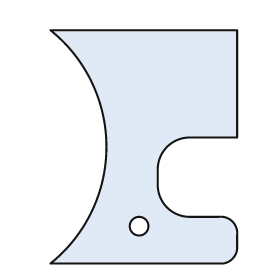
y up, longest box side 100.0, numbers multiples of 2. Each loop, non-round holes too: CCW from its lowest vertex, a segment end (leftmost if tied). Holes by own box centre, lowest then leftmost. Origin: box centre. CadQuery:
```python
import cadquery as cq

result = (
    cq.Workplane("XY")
    .moveTo(-40.0, -50.0)
    .lineTo(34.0, -50.0)
    .threePointArc((38.0, -48.0), (40.0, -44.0))
    .lineTo(40.0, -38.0)
    .threePointArc((38.0, -32.0), (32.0, -30.0))
    .lineTo(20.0, -30.0)
    .threePointArc((10.0, -26.0), (6.0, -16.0))
    .lineTo(6.0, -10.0)
    .threePointArc((10.0, 0.0), (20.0, 4.0))
    .lineTo(40.0, 4.0)
    .lineTo(40.0, 50.0)
    .lineTo(-40.0, 50.0)
    .threePointArc((-16.0, 0.0), (-40.0, -50.0))
    .close()
    .moveTo(-2.0, -34.0)
    .circle(4.0)
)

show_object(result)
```